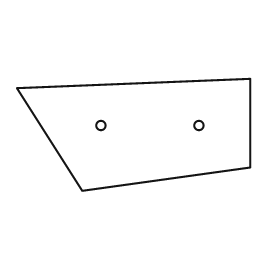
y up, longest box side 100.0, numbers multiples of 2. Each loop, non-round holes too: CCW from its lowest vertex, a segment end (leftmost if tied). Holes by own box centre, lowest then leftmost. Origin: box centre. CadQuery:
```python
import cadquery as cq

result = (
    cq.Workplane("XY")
    .moveTo(-22.0, -24.0)
    .lineTo(50.0, -14.0)
    .lineTo(50.0, 24.0)
    .lineTo(-50.0, 20.0)
    .close()
    .moveTo(-14.0, 4.0)
    .circle(2.0)
    .moveTo(28.0, 4.0)
    .circle(2.0)
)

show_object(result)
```